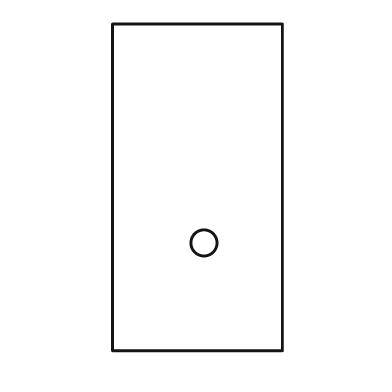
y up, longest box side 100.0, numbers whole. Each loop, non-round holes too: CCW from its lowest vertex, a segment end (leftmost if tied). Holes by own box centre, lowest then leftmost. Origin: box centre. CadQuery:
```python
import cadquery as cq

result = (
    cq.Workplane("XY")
    .moveTo(-26.0, -50.0)
    .lineTo(26.0, -50.0)
    .lineTo(26.0, 50.0)
    .lineTo(-26.0, 50.0)
    .close()
    .moveTo(2.0, -17.0)
    .circle(4.0)
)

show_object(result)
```